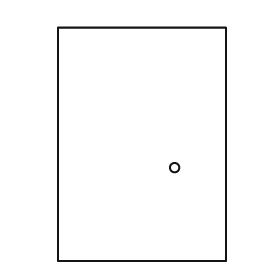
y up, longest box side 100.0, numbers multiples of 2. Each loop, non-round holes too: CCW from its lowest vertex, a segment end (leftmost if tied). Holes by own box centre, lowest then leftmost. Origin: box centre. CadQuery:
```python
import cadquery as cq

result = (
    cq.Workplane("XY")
    .moveTo(-36.0, -50.0)
    .lineTo(36.0, -50.0)
    .lineTo(36.0, 50.0)
    .lineTo(-36.0, 50.0)
    .close()
    .moveTo(14.0, -10.0)
    .circle(2.0)
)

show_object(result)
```